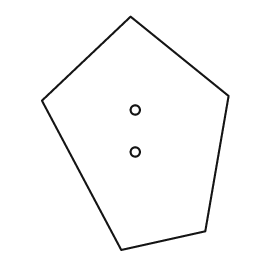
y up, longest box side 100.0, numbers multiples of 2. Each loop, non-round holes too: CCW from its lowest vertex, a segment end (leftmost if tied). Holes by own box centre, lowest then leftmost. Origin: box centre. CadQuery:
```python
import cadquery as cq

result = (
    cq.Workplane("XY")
    .moveTo(-6.0, -50.0)
    .lineTo(30.0, -42.0)
    .lineTo(40.0, 16.0)
    .lineTo(-2.0, 50.0)
    .lineTo(-40.0, 14.0)
    .close()
    .moveTo(0.0, -8.0)
    .circle(2.0)
    .moveTo(0.0, 10.0)
    .circle(2.0)
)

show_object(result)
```